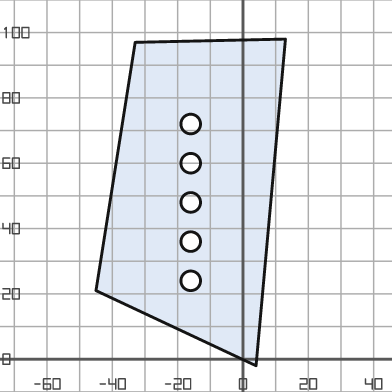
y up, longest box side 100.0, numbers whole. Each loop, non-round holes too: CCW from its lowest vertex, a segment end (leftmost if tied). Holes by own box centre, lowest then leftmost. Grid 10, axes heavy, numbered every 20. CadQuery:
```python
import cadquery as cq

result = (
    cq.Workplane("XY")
    .moveTo(4.0, -2.0)
    .lineTo(13.0, 98.0)
    .lineTo(-33.0, 97.0)
    .lineTo(-45.0, 21.0)
    .close()
    .moveTo(-16.0, 24.0)
    .circle(3.0)
    .moveTo(-16.0, 36.0)
    .circle(3.0)
    .moveTo(-16.0, 48.0)
    .circle(3.0)
    .moveTo(-16.0, 60.0)
    .circle(3.0)
    .moveTo(-16.0, 72.0)
    .circle(3.0)
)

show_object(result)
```